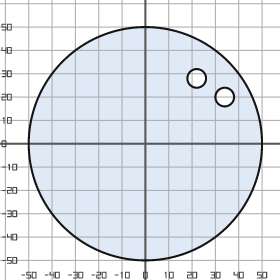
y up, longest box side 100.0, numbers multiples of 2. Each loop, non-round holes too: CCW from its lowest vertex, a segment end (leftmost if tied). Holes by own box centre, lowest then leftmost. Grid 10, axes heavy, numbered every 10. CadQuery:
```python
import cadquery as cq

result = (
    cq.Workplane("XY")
    .moveTo(0.0, 0.0)
    .circle(50.0)
    .moveTo(34.0, 20.0)
    .circle(4.0)
    .moveTo(22.0, 28.0)
    .circle(4.0)
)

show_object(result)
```